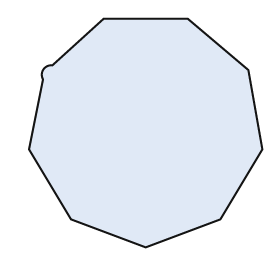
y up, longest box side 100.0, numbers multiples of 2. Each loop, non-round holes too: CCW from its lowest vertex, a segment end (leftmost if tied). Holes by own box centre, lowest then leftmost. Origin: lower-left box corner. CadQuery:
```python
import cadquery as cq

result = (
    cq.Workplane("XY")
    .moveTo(50.0, 0.0)
    .lineTo(82.0, 12.0)
    .lineTo(100.0, 42.0)
    .lineTo(94.0, 76.0)
    .lineTo(68.0, 98.0)
    .lineTo(32.0, 98.0)
    .lineTo(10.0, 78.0)
    .threePointArc((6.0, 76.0), (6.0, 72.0))
    .lineTo(0.0, 42.0)
    .lineTo(18.0, 12.0)
    .close()
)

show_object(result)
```